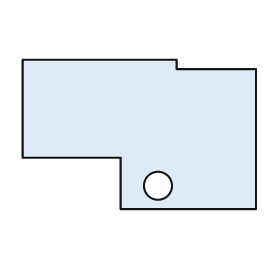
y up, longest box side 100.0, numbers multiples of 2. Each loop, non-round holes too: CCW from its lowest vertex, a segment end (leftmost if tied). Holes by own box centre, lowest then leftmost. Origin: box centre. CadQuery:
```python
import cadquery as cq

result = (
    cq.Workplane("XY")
    .moveTo(-8.0, -32.0)
    .lineTo(50.0, -32.0)
    .lineTo(50.0, 28.0)
    .lineTo(16.0, 28.0)
    .lineTo(16.0, 32.0)
    .lineTo(-50.0, 32.0)
    .lineTo(-50.0, -10.0)
    .lineTo(-8.0, -10.0)
    .close()
    .moveTo(8.0, -22.0)
    .circle(6.0)
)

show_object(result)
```